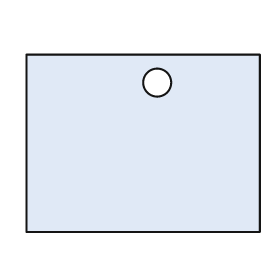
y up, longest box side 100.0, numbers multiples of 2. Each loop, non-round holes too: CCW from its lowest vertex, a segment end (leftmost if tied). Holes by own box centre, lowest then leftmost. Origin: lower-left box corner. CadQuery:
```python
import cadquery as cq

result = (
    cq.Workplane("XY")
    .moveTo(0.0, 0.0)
    .lineTo(100.0, 0.0)
    .lineTo(100.0, 76.0)
    .lineTo(0.0, 76.0)
    .close()
    .moveTo(56.0, 64.0)
    .circle(6.0)
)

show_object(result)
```